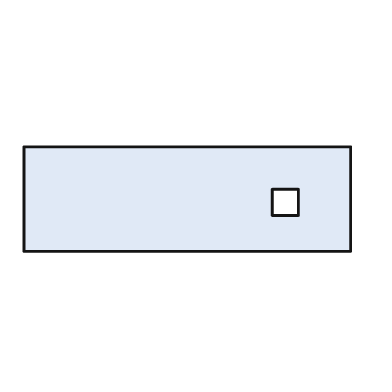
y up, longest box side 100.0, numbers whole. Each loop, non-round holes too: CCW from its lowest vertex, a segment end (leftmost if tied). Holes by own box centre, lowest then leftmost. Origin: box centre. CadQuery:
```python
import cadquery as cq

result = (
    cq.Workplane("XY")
    .moveTo(-50.0, -16.0)
    .lineTo(50.0, -16.0)
    .lineTo(50.0, 16.0)
    .lineTo(-50.0, 16.0)
    .close()
    .moveTo(26.0, -5.0)
    .lineTo(34.0, -5.0)
    .lineTo(34.0, 3.0)
    .lineTo(26.0, 3.0)
    .close()
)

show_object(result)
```